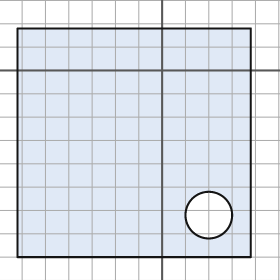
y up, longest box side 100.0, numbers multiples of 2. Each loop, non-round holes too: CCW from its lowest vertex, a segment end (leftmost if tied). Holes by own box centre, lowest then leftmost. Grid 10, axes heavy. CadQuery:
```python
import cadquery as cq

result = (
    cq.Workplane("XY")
    .moveTo(-62.0, -80.0)
    .lineTo(38.0, -80.0)
    .lineTo(38.0, 18.0)
    .lineTo(-62.0, 18.0)
    .close()
    .moveTo(20.0, -62.0)
    .circle(10.0)
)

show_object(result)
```